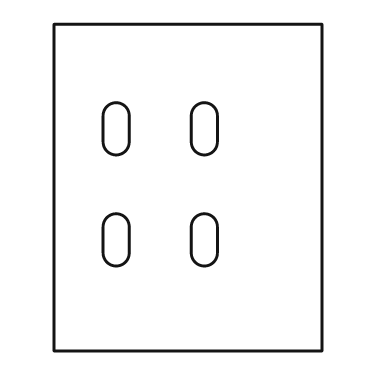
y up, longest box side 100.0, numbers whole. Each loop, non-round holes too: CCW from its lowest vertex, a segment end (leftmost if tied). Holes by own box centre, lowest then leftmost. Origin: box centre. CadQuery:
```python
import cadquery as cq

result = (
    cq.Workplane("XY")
    .moveTo(-41.0, -50.0)
    .lineTo(41.0, -50.0)
    .lineTo(41.0, 50.0)
    .lineTo(-41.0, 50.0)
    .close()
    .moveTo(-26.0, -20.0)
    .threePointArc((-22.0, -24.0), (-18.0, -20.0))
    .lineTo(-18.0, -12.0)
    .threePointArc((-22.0, -8.0), (-26.0, -12.0))
    .close()
    .moveTo(1.0, -20.0)
    .threePointArc((5.0, -24.0), (9.0, -20.0))
    .lineTo(9.0, -12.0)
    .threePointArc((5.0, -8.0), (1.0, -12.0))
    .close()
    .moveTo(-26.0, 14.0)
    .threePointArc((-22.0, 10.0), (-18.0, 14.0))
    .lineTo(-18.0, 22.0)
    .threePointArc((-22.0, 26.0), (-26.0, 22.0))
    .close()
    .moveTo(1.0, 14.0)
    .threePointArc((5.0, 10.0), (9.0, 14.0))
    .lineTo(9.0, 22.0)
    .threePointArc((5.0, 26.0), (1.0, 22.0))
    .close()
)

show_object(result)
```